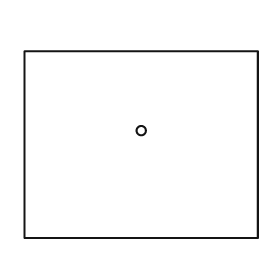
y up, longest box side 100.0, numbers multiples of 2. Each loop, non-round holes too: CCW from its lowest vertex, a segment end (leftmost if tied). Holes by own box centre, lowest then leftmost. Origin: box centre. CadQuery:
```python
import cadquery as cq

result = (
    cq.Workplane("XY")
    .moveTo(-50.0, -40.0)
    .lineTo(50.0, -40.0)
    .lineTo(50.0, 40.0)
    .lineTo(-50.0, 40.0)
    .close()
    .moveTo(0.0, 6.0)
    .circle(2.0)
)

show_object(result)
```